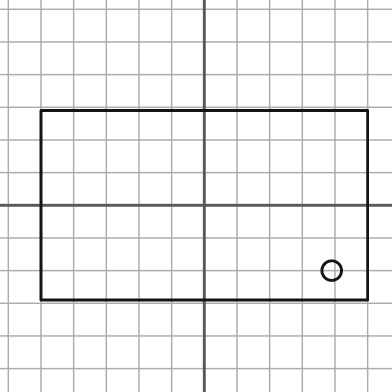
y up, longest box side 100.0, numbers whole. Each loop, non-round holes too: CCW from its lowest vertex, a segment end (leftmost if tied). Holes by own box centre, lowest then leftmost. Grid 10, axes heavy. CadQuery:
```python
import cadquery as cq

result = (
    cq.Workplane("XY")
    .moveTo(-50.0, -29.0)
    .lineTo(50.0, -29.0)
    .lineTo(50.0, 29.0)
    .lineTo(-50.0, 29.0)
    .close()
    .moveTo(39.0, -20.0)
    .circle(3.0)
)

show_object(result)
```